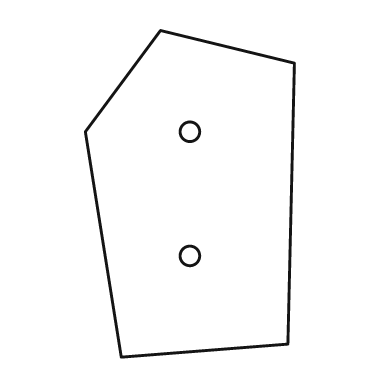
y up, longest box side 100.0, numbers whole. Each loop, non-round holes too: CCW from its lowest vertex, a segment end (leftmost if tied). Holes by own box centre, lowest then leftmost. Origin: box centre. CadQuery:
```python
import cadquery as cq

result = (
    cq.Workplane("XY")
    .moveTo(-21.0, -50.0)
    .lineTo(30.0, -46.0)
    .lineTo(32.0, 40.0)
    .lineTo(-9.0, 50.0)
    .lineTo(-32.0, 19.0)
    .close()
    .moveTo(0.0, -19.0)
    .circle(3.0)
    .moveTo(0.0, 19.0)
    .circle(3.0)
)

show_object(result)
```